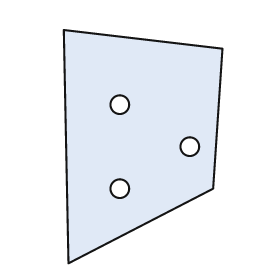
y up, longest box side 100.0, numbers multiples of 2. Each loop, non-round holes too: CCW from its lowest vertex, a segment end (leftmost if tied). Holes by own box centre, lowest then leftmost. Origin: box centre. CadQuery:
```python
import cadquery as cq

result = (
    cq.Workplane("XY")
    .moveTo(-32.0, -50.0)
    .lineTo(30.0, -18.0)
    .lineTo(34.0, 42.0)
    .lineTo(-34.0, 50.0)
    .close()
    .moveTo(-10.0, -18.0)
    .circle(4.0)
    .moveTo(20.0, 0.0)
    .circle(4.0)
    .moveTo(-10.0, 18.0)
    .circle(4.0)
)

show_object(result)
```